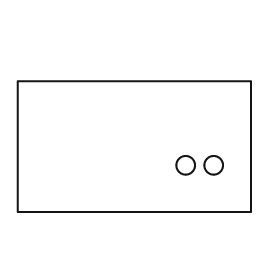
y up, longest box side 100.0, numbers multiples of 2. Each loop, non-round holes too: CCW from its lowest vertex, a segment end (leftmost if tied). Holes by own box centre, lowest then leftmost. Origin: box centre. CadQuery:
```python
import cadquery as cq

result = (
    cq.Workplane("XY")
    .moveTo(-50.0, -28.0)
    .lineTo(50.0, -28.0)
    .lineTo(50.0, 28.0)
    .lineTo(-50.0, 28.0)
    .close()
    .moveTo(22.0, -8.0)
    .circle(4.0)
    .moveTo(34.0, -8.0)
    .circle(4.0)
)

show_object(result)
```